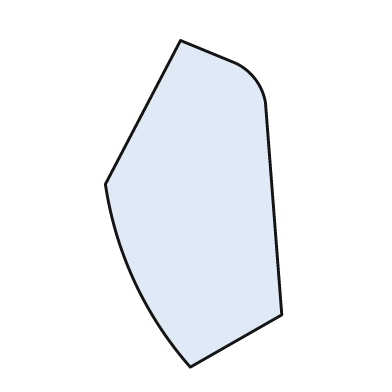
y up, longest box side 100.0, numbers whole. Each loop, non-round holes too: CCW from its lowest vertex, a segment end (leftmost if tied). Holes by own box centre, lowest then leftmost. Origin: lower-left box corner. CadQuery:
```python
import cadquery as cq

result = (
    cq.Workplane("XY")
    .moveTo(26.0, 0.0)
    .lineTo(54.0, 16.0)
    .lineTo(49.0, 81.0)
    .threePointArc((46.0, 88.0), (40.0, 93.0))
    .lineTo(23.0, 100.0)
    .lineTo(0.0, 56.0)
    .threePointArc((9.0, 26.0), (26.0, 0.0))
    .close()
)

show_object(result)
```